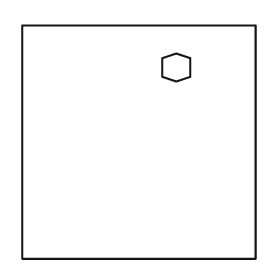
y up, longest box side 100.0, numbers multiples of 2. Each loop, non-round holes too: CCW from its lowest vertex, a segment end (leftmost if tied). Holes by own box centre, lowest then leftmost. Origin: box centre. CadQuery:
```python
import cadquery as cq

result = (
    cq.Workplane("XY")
    .moveTo(-50.0, -50.0)
    .lineTo(50.0, -50.0)
    .lineTo(50.0, 50.0)
    .lineTo(-50.0, 50.0)
    .close()
    .moveTo(16.0, 26.0)
    .lineTo(22.0, 28.0)
    .lineTo(22.0, 36.0)
    .lineTo(16.0, 38.0)
    .lineTo(10.0, 36.0)
    .lineTo(10.0, 28.0)
    .close()
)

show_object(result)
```